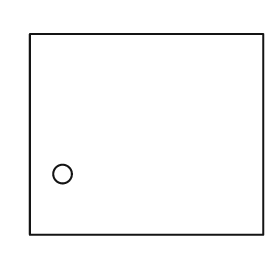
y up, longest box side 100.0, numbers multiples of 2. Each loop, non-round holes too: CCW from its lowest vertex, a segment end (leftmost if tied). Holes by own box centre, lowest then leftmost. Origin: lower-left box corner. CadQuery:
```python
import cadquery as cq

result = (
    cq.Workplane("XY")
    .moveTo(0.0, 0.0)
    .lineTo(100.0, 0.0)
    .lineTo(100.0, 86.0)
    .lineTo(0.0, 86.0)
    .close()
    .moveTo(14.0, 26.0)
    .circle(4.0)
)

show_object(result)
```